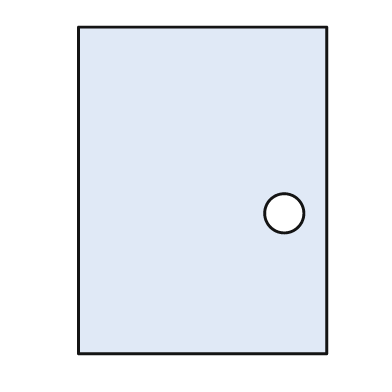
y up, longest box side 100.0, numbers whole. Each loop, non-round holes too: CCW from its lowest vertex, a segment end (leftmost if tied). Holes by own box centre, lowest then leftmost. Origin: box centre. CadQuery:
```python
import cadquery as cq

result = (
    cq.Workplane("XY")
    .moveTo(-38.0, -50.0)
    .lineTo(38.0, -50.0)
    .lineTo(38.0, 50.0)
    .lineTo(-38.0, 50.0)
    .close()
    .moveTo(25.0, -7.0)
    .circle(6.0)
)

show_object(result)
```